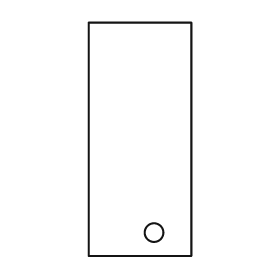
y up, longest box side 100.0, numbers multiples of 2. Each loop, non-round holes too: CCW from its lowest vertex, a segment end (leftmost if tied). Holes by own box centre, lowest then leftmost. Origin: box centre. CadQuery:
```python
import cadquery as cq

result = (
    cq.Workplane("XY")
    .moveTo(-22.0, -50.0)
    .lineTo(22.0, -50.0)
    .lineTo(22.0, 50.0)
    .lineTo(-22.0, 50.0)
    .close()
    .moveTo(6.0, -40.0)
    .circle(4.0)
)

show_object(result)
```